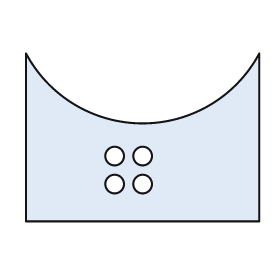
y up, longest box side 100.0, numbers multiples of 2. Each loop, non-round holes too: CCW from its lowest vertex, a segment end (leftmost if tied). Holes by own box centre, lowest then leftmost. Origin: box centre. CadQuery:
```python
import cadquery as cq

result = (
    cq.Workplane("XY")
    .moveTo(-50.0, -36.0)
    .lineTo(50.0, -36.0)
    .lineTo(50.0, 36.0)
    .threePointArc((0.0, 6.0), (-50.0, 36.0))
    .close()
    .moveTo(-12.0, -20.0)
    .circle(4.0)
    .moveTo(0.0, -20.0)
    .circle(4.0)
    .moveTo(-12.0, -8.0)
    .circle(4.0)
    .moveTo(0.0, -8.0)
    .circle(4.0)
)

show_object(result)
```